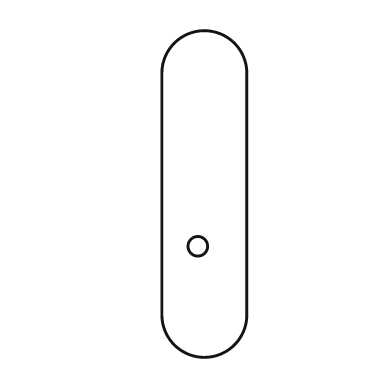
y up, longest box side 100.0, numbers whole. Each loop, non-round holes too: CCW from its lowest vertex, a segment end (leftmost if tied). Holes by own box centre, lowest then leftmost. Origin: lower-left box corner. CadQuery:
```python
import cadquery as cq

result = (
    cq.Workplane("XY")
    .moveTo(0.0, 13.0)
    .threePointArc((13.0, 0.0), (26.0, 13.0))
    .lineTo(26.0, 87.0)
    .threePointArc((13.0, 100.0), (0.0, 87.0))
    .close()
    .moveTo(11.0, 34.0)
    .circle(3.0)
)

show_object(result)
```